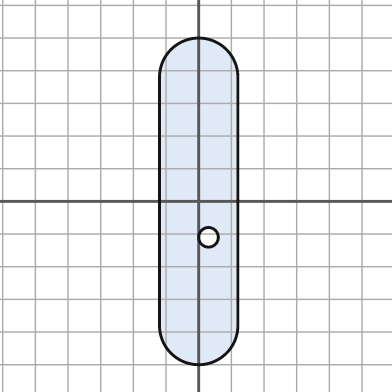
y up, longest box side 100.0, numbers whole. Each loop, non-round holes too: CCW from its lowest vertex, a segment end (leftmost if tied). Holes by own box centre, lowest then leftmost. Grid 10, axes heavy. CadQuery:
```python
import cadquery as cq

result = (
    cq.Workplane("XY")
    .moveTo(-12.0, -38.0)
    .threePointArc((0.0, -50.0), (12.0, -38.0))
    .lineTo(12.0, 38.0)
    .threePointArc((0.0, 50.0), (-12.0, 38.0))
    .close()
    .moveTo(3.0, -11.0)
    .circle(3.0)
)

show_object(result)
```